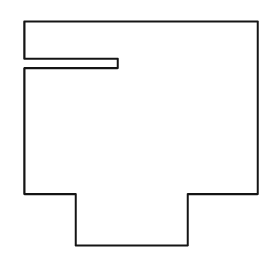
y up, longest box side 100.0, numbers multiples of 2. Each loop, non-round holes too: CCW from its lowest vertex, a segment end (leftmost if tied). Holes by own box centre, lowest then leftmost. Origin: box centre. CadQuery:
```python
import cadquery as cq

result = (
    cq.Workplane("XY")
    .moveTo(-28.0, -48.0)
    .lineTo(20.0, -48.0)
    .lineTo(20.0, -26.0)
    .lineTo(50.0, -26.0)
    .lineTo(50.0, 48.0)
    .lineTo(-50.0, 48.0)
    .lineTo(-50.0, 32.0)
    .lineTo(-10.0, 32.0)
    .lineTo(-10.0, 28.0)
    .lineTo(-50.0, 28.0)
    .lineTo(-50.0, -26.0)
    .lineTo(-28.0, -26.0)
    .close()
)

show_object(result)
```